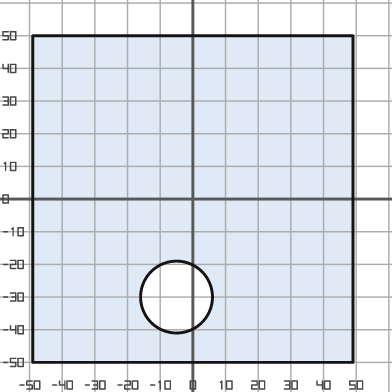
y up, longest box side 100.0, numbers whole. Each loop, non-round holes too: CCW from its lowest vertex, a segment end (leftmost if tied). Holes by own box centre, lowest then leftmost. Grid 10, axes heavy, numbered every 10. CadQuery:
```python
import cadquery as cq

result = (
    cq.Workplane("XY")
    .moveTo(-49.0, -50.0)
    .lineTo(49.0, -50.0)
    .lineTo(49.0, 50.0)
    .lineTo(-49.0, 50.0)
    .close()
    .moveTo(-5.0, -30.0)
    .circle(11.0)
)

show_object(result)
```